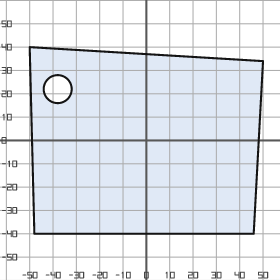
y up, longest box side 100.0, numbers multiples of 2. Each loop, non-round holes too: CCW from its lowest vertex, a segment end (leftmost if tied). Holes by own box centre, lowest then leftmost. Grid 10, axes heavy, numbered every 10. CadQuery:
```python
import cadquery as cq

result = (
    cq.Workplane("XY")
    .moveTo(-48.0, -40.0)
    .lineTo(46.0, -40.0)
    .lineTo(50.0, 34.0)
    .lineTo(-50.0, 40.0)
    .close()
    .moveTo(-38.0, 22.0)
    .circle(6.0)
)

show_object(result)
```